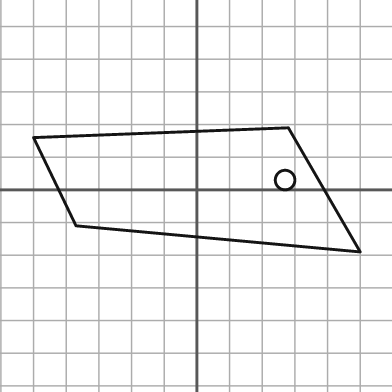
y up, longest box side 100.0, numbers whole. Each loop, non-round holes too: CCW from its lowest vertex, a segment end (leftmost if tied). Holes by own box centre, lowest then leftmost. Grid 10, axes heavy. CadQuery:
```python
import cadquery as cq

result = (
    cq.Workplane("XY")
    .moveTo(50.0, -19.0)
    .lineTo(28.0, 19.0)
    .lineTo(-50.0, 16.0)
    .lineTo(-37.0, -11.0)
    .close()
    .moveTo(27.0, 3.0)
    .circle(3.0)
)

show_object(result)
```